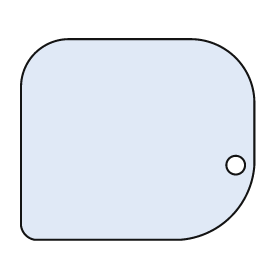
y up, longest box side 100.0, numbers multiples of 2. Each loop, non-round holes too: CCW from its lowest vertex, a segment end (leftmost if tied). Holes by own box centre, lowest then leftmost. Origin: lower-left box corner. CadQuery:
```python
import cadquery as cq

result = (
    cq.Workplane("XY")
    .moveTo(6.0, 0.0)
    .lineTo(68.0, 0.0)
    .threePointArc((90.0, 10.0), (100.0, 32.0))
    .lineTo(100.0, 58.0)
    .threePointArc((92.0, 78.0), (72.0, 86.0))
    .lineTo(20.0, 86.0)
    .threePointArc((6.0, 80.0), (0.0, 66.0))
    .lineTo(0.0, 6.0)
    .threePointArc((2.0, 2.0), (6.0, 0.0))
    .close()
    .moveTo(92.0, 32.0)
    .circle(4.0)
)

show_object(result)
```